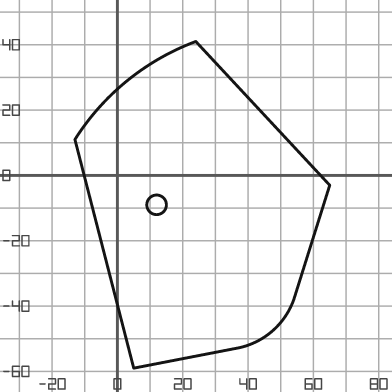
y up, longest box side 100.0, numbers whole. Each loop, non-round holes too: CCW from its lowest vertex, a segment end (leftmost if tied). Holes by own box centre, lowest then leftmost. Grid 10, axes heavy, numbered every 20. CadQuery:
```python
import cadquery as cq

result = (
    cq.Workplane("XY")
    .moveTo(5.0, -59.0)
    .lineTo(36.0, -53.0)
    .threePointArc((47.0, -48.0), (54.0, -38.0))
    .lineTo(65.0, -3.0)
    .lineTo(24.0, 41.0)
    .threePointArc((3.0, 29.0), (-13.0, 11.0))
    .close()
    .moveTo(12.0, -9.0)
    .circle(3.0)
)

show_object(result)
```